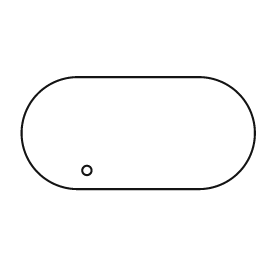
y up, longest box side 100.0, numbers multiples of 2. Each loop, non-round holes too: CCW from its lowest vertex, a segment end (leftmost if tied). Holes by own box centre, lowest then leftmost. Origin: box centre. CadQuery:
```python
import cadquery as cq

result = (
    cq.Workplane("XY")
    .moveTo(-26.0, -24.0)
    .lineTo(26.0, -24.0)
    .threePointArc((50.0, 0.0), (26.0, 24.0))
    .lineTo(-26.0, 24.0)
    .threePointArc((-50.0, 0.0), (-26.0, -24.0))
    .close()
    .moveTo(-22.0, -16.0)
    .circle(2.0)
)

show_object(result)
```